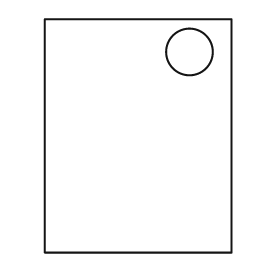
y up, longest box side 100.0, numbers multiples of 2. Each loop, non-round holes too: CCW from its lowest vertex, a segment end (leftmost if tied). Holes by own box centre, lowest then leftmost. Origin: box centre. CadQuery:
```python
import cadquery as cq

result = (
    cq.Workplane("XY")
    .moveTo(-40.0, -50.0)
    .lineTo(40.0, -50.0)
    .lineTo(40.0, 50.0)
    .lineTo(-40.0, 50.0)
    .close()
    .moveTo(22.0, 36.0)
    .circle(10.0)
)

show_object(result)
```